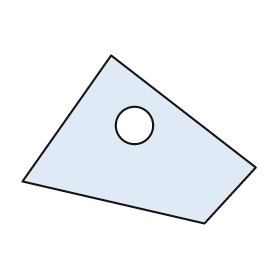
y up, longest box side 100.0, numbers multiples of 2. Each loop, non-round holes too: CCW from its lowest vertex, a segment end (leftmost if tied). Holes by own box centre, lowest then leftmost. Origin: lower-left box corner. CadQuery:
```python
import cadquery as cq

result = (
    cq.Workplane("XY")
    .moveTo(78.0, 0.0)
    .lineTo(100.0, 24.0)
    .lineTo(38.0, 72.0)
    .lineTo(0.0, 18.0)
    .close()
    .moveTo(48.0, 42.0)
    .circle(8.0)
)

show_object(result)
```